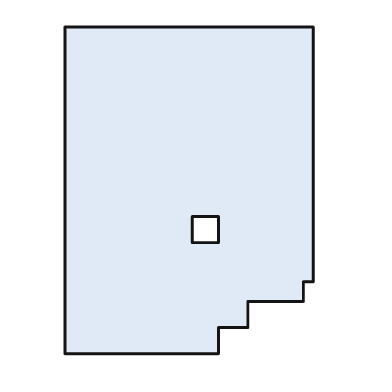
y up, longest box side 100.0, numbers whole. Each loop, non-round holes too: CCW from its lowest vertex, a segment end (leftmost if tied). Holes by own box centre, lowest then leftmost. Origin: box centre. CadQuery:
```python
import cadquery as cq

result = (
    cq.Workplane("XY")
    .moveTo(-38.0, -50.0)
    .lineTo(9.0, -50.0)
    .lineTo(9.0, -42.0)
    .lineTo(18.0, -42.0)
    .lineTo(18.0, -34.0)
    .lineTo(35.0, -34.0)
    .lineTo(35.0, -28.0)
    .lineTo(38.0, -28.0)
    .lineTo(38.0, 50.0)
    .lineTo(-38.0, 50.0)
    .close()
    .moveTo(1.0, -16.0)
    .lineTo(9.0, -16.0)
    .lineTo(9.0, -8.0)
    .lineTo(1.0, -8.0)
    .close()
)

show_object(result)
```